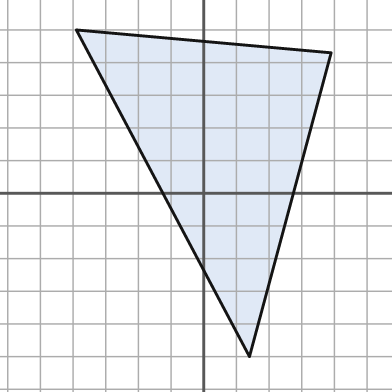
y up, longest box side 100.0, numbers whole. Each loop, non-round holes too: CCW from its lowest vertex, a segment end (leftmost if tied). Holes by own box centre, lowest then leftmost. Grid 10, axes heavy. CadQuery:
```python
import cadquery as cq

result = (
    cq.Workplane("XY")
    .moveTo(14.0, -50.0)
    .lineTo(39.0, 43.0)
    .lineTo(-39.0, 50.0)
    .close()
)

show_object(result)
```